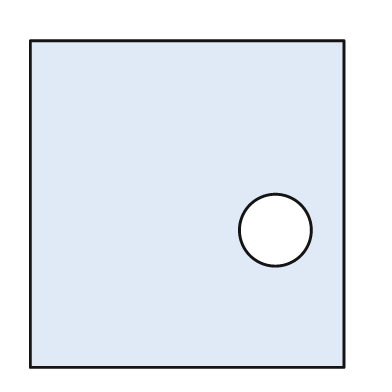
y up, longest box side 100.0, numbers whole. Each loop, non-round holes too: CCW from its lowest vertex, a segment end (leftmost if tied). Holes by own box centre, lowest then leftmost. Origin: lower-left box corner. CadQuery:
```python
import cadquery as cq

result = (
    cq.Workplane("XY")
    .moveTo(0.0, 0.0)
    .lineTo(96.0, 0.0)
    .lineTo(96.0, 100.0)
    .lineTo(0.0, 100.0)
    .close()
    .moveTo(75.0, 42.0)
    .circle(11.0)
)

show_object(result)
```